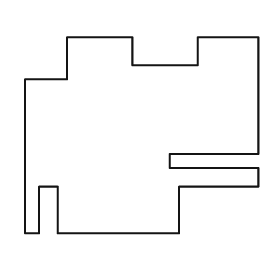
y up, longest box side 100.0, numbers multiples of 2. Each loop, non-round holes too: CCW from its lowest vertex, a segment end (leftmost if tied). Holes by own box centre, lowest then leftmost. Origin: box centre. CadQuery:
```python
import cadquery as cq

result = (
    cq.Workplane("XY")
    .moveTo(-50.0, -42.0)
    .lineTo(-44.0, -42.0)
    .lineTo(-44.0, -22.0)
    .lineTo(-36.0, -22.0)
    .lineTo(-36.0, -42.0)
    .lineTo(16.0, -42.0)
    .lineTo(16.0, -22.0)
    .lineTo(50.0, -22.0)
    .lineTo(50.0, -14.0)
    .lineTo(12.0, -14.0)
    .lineTo(12.0, -8.0)
    .lineTo(50.0, -8.0)
    .lineTo(50.0, 42.0)
    .lineTo(24.0, 42.0)
    .lineTo(24.0, 30.0)
    .lineTo(-4.0, 30.0)
    .lineTo(-4.0, 42.0)
    .lineTo(-32.0, 42.0)
    .lineTo(-32.0, 24.0)
    .lineTo(-50.0, 24.0)
    .close()
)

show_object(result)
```